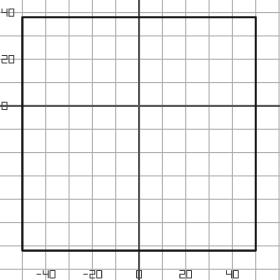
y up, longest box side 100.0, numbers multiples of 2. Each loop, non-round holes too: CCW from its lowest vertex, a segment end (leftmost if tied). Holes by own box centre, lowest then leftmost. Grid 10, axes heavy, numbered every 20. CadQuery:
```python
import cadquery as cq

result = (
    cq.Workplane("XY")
    .moveTo(-50.0, -62.0)
    .lineTo(50.0, -62.0)
    .lineTo(50.0, 38.0)
    .lineTo(-50.0, 38.0)
    .close()
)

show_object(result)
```